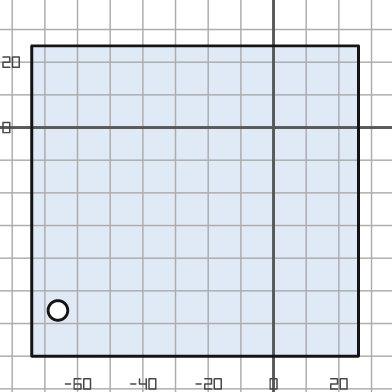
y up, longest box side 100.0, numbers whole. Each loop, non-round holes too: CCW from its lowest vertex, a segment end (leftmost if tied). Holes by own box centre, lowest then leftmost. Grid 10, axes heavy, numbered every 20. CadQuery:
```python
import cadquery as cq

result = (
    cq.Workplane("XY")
    .moveTo(-74.0, -70.0)
    .lineTo(26.0, -70.0)
    .lineTo(26.0, 25.0)
    .lineTo(-74.0, 25.0)
    .close()
    .moveTo(-66.0, -56.0)
    .circle(3.0)
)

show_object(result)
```